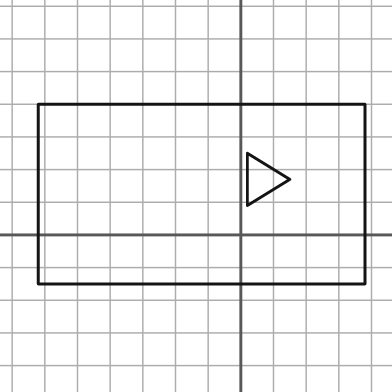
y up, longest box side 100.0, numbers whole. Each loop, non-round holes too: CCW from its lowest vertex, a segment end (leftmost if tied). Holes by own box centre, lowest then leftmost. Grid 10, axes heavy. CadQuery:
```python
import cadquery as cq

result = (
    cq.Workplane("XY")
    .moveTo(-62.0, -15.0)
    .lineTo(38.0, -15.0)
    .lineTo(38.0, 40.0)
    .lineTo(-62.0, 40.0)
    .close()
    .moveTo(2.0, 9.0)
    .lineTo(15.0, 17.0)
    .lineTo(2.0, 25.0)
    .close()
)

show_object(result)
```